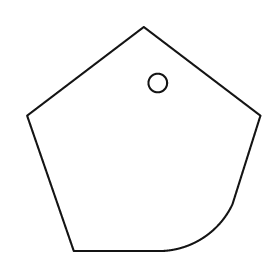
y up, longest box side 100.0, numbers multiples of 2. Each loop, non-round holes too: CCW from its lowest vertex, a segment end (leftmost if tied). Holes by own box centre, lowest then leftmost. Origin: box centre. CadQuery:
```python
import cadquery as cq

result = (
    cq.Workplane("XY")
    .moveTo(-30.0, -48.0)
    .lineTo(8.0, -48.0)
    .threePointArc((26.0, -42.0), (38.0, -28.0))
    .lineTo(50.0, 10.0)
    .lineTo(0.0, 48.0)
    .lineTo(-50.0, 10.0)
    .close()
    .moveTo(6.0, 24.0)
    .circle(4.0)
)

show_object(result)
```